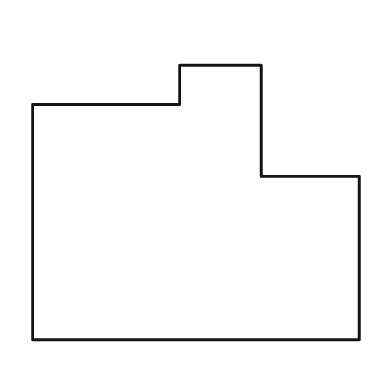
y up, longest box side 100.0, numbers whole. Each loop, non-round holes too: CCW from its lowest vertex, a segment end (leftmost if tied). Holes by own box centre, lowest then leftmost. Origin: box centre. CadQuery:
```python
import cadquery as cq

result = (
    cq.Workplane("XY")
    .moveTo(-50.0, -42.0)
    .lineTo(50.0, -42.0)
    .lineTo(50.0, 8.0)
    .lineTo(20.0, 8.0)
    .lineTo(20.0, 42.0)
    .lineTo(-5.0, 42.0)
    .lineTo(-5.0, 30.0)
    .lineTo(-50.0, 30.0)
    .close()
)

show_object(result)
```